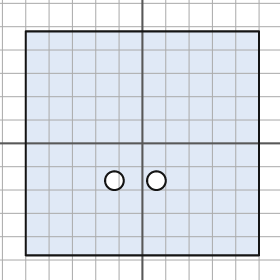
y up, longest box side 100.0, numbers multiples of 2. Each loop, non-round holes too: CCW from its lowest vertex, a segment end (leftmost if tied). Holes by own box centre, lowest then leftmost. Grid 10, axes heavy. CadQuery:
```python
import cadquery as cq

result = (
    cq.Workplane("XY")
    .moveTo(-50.0, -48.0)
    .lineTo(50.0, -48.0)
    .lineTo(50.0, 48.0)
    .lineTo(-50.0, 48.0)
    .close()
    .moveTo(-12.0, -16.0)
    .circle(4.0)
    .moveTo(6.0, -16.0)
    .circle(4.0)
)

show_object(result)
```